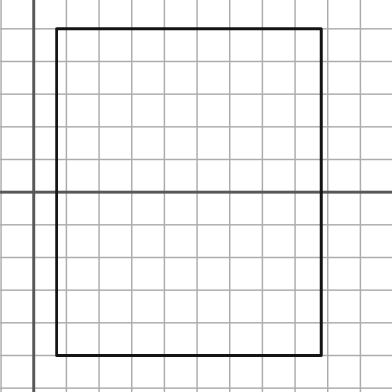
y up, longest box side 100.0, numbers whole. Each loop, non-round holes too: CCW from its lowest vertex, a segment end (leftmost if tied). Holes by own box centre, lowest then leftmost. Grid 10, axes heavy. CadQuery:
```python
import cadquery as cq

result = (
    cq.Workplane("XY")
    .moveTo(7.0, -50.0)
    .lineTo(88.0, -50.0)
    .lineTo(88.0, 50.0)
    .lineTo(7.0, 50.0)
    .close()
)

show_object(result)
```